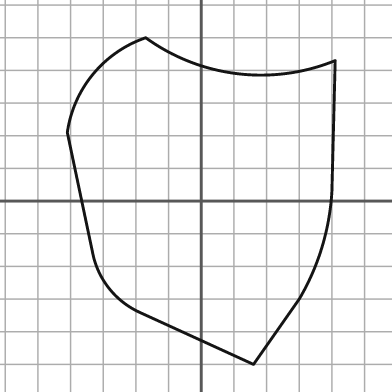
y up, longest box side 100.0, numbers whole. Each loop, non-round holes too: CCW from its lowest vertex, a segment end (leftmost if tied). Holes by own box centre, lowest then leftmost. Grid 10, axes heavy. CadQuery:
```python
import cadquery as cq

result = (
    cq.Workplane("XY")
    .moveTo(16.0, -50.0)
    .lineTo(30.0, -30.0)
    .threePointArc((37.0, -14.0), (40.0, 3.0))
    .lineTo(41.0, 43.0)
    .threePointArc((11.0, 39.0), (-17.0, 50.0))
    .threePointArc((-33.0, 39.0), (-41.0, 21.0))
    .lineTo(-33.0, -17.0)
    .threePointArc((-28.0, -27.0), (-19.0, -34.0))
    .close()
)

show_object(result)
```